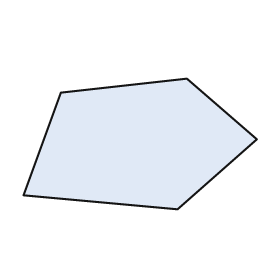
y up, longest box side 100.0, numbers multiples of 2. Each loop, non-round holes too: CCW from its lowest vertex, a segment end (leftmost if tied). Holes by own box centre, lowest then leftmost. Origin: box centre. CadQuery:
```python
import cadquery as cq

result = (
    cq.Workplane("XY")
    .moveTo(16.0, -28.0)
    .lineTo(50.0, 2.0)
    .lineTo(20.0, 28.0)
    .lineTo(-34.0, 22.0)
    .lineTo(-50.0, -22.0)
    .close()
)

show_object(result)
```